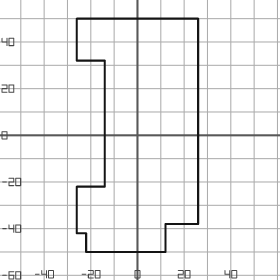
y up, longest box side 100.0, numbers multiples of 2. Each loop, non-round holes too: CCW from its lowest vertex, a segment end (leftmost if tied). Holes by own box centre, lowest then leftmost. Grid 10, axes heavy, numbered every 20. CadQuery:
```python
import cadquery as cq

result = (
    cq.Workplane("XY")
    .moveTo(-22.0, -50.0)
    .lineTo(12.0, -50.0)
    .lineTo(12.0, -38.0)
    .lineTo(26.0, -38.0)
    .lineTo(26.0, 50.0)
    .lineTo(-26.0, 50.0)
    .lineTo(-26.0, 32.0)
    .lineTo(-14.0, 32.0)
    .lineTo(-14.0, -22.0)
    .lineTo(-26.0, -22.0)
    .lineTo(-26.0, -42.0)
    .lineTo(-22.0, -42.0)
    .close()
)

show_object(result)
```